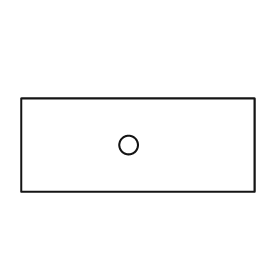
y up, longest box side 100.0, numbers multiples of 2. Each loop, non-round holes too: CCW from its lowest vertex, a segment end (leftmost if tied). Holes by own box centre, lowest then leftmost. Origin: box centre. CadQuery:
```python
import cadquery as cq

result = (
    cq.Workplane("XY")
    .moveTo(-50.0, -20.0)
    .lineTo(50.0, -20.0)
    .lineTo(50.0, 20.0)
    .lineTo(-50.0, 20.0)
    .close()
    .moveTo(-4.0, 0.0)
    .circle(4.0)
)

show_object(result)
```